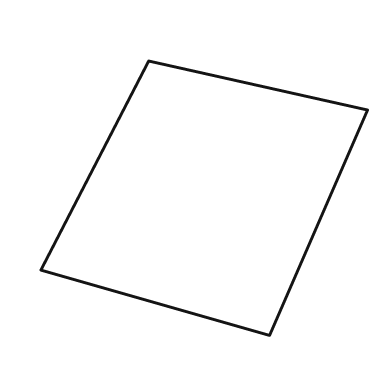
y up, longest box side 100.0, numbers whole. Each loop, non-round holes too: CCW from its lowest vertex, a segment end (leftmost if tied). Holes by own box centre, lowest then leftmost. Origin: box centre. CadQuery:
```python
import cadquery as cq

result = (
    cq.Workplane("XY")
    .moveTo(20.0, -42.0)
    .lineTo(50.0, 27.0)
    .lineTo(-17.0, 42.0)
    .lineTo(-50.0, -22.0)
    .close()
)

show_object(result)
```